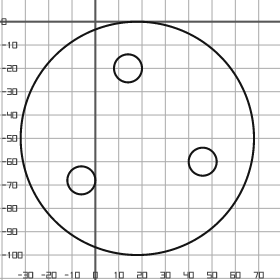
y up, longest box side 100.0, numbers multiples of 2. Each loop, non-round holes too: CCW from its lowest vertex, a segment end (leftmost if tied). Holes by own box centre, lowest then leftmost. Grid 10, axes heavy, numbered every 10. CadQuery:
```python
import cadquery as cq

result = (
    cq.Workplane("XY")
    .moveTo(18.0, -50.0)
    .circle(50.0)
    .moveTo(-6.0, -68.0)
    .circle(6.0)
    .moveTo(46.0, -60.0)
    .circle(6.0)
    .moveTo(14.0, -20.0)
    .circle(6.0)
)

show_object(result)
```